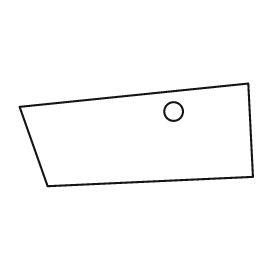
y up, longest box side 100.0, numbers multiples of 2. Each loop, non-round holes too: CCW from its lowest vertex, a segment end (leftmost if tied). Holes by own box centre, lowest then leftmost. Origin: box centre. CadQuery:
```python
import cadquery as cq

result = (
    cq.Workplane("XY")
    .moveTo(-38.0, -22.0)
    .lineTo(50.0, -18.0)
    .lineTo(48.0, 22.0)
    .lineTo(-50.0, 12.0)
    .close()
    .moveTo(16.0, 10.0)
    .circle(4.0)
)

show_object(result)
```